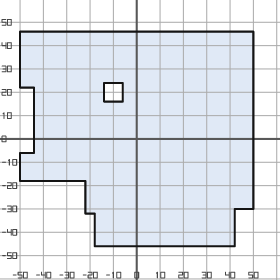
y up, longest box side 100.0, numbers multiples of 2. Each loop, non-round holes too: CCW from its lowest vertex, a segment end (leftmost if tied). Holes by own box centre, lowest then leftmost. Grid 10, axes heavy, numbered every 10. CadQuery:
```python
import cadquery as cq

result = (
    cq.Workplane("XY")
    .moveTo(-18.0, -46.0)
    .lineTo(42.0, -46.0)
    .lineTo(42.0, -30.0)
    .lineTo(50.0, -30.0)
    .lineTo(50.0, 46.0)
    .lineTo(-50.0, 46.0)
    .lineTo(-50.0, 22.0)
    .lineTo(-44.0, 22.0)
    .lineTo(-44.0, -6.0)
    .lineTo(-50.0, -6.0)
    .lineTo(-50.0, -18.0)
    .lineTo(-22.0, -18.0)
    .lineTo(-22.0, -32.0)
    .lineTo(-18.0, -32.0)
    .close()
    .moveTo(-14.0, 16.0)
    .lineTo(-6.0, 16.0)
    .lineTo(-6.0, 24.0)
    .lineTo(-14.0, 24.0)
    .close()
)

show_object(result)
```